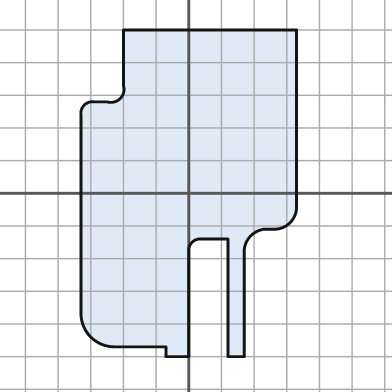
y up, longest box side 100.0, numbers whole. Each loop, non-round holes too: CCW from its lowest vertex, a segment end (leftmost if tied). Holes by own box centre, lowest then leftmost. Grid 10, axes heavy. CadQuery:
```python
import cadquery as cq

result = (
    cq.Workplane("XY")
    .moveTo(-7.0, -50.0)
    .lineTo(0.0, -50.0)
    .lineTo(0.0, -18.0)
    .threePointArc((1.0, -15.0), (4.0, -14.0))
    .lineTo(12.0, -14.0)
    .lineTo(12.0, -50.0)
    .lineTo(17.0, -50.0)
    .lineTo(17.0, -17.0)
    .threePointArc((19.0, -13.0), (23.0, -11.0))
    .lineTo(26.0, -11.0)
    .threePointArc((31.0, -9.0), (33.0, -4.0))
    .lineTo(33.0, 50.0)
    .lineTo(-20.0, 50.0)
    .lineTo(-20.0, 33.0)
    .threePointArc((-21.0, 29.0), (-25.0, 28.0))
    .lineTo(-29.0, 28.0)
    .threePointArc((-32.0, 27.0), (-33.0, 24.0))
    .lineTo(-33.0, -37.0)
    .threePointArc((-30.0, -44.0), (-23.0, -47.0))
    .lineTo(-7.0, -47.0)
    .close()
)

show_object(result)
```